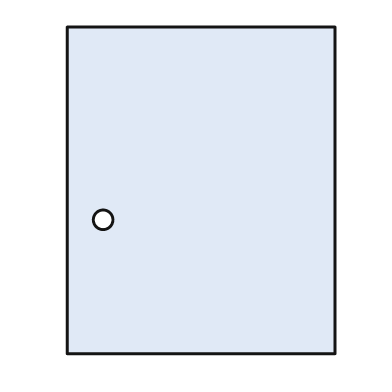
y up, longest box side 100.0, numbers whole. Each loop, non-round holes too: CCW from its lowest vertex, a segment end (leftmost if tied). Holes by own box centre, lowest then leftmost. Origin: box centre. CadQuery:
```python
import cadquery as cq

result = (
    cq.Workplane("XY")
    .moveTo(-41.0, -50.0)
    .lineTo(41.0, -50.0)
    .lineTo(41.0, 50.0)
    .lineTo(-41.0, 50.0)
    .close()
    .moveTo(-30.0, -9.0)
    .circle(3.0)
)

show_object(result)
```